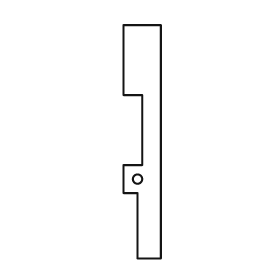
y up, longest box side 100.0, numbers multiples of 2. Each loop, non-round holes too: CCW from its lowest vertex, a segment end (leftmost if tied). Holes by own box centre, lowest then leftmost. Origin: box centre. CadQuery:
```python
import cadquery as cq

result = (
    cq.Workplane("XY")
    .moveTo(-2.0, -50.0)
    .lineTo(8.0, -50.0)
    .lineTo(8.0, 50.0)
    .lineTo(-8.0, 50.0)
    .lineTo(-8.0, 20.0)
    .lineTo(0.0, 20.0)
    .lineTo(0.0, -10.0)
    .lineTo(-8.0, -10.0)
    .lineTo(-8.0, -22.0)
    .lineTo(-2.0, -22.0)
    .close()
    .moveTo(-2.0, -16.0)
    .circle(2.0)
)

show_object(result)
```